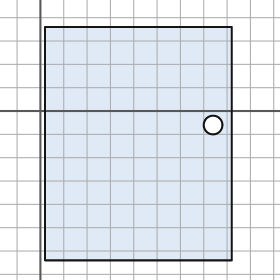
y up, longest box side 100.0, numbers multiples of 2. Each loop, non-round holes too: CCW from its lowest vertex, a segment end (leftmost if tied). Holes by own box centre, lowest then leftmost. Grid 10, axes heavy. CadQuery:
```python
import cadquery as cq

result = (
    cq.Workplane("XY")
    .moveTo(2.0, -64.0)
    .lineTo(82.0, -64.0)
    .lineTo(82.0, 36.0)
    .lineTo(2.0, 36.0)
    .close()
    .moveTo(74.0, -6.0)
    .circle(4.0)
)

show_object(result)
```